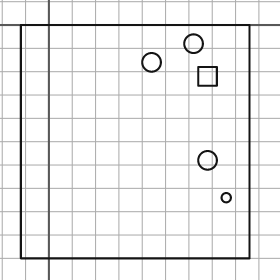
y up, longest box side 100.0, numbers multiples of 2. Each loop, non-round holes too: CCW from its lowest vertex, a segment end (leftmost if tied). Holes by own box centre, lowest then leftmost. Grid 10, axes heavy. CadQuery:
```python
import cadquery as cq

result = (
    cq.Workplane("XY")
    .moveTo(-12.0, -100.0)
    .lineTo(86.0, -100.0)
    .lineTo(86.0, 0.0)
    .lineTo(-12.0, 0.0)
    .close()
    .moveTo(76.0, -74.0)
    .circle(2.0)
    .moveTo(68.0, -58.0)
    .circle(4.0)
    .moveTo(64.0, -26.0)
    .lineTo(72.0, -26.0)
    .lineTo(72.0, -18.0)
    .lineTo(64.0, -18.0)
    .close()
    .moveTo(44.0, -16.0)
    .circle(4.0)
    .moveTo(62.0, -8.0)
    .circle(4.0)
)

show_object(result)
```